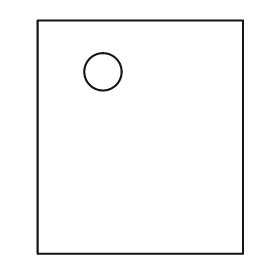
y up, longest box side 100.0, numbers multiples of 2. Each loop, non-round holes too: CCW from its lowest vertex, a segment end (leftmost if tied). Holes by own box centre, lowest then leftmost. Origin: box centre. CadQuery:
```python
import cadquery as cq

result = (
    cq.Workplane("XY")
    .moveTo(-44.0, -50.0)
    .lineTo(44.0, -50.0)
    .lineTo(44.0, 50.0)
    .lineTo(-44.0, 50.0)
    .close()
    .moveTo(-16.0, 28.0)
    .circle(8.0)
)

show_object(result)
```